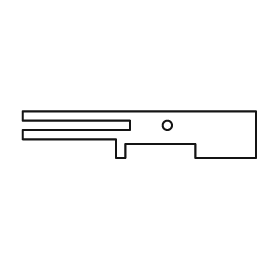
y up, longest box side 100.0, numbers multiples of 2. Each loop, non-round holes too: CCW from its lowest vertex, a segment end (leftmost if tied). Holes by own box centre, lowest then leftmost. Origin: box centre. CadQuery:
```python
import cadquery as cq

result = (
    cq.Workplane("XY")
    .moveTo(-10.0, -10.0)
    .lineTo(-6.0, -10.0)
    .lineTo(-6.0, -4.0)
    .lineTo(24.0, -4.0)
    .lineTo(24.0, -10.0)
    .lineTo(50.0, -10.0)
    .lineTo(50.0, 10.0)
    .lineTo(-50.0, 10.0)
    .lineTo(-50.0, 6.0)
    .lineTo(-4.0, 6.0)
    .lineTo(-4.0, 2.0)
    .lineTo(-50.0, 2.0)
    .lineTo(-50.0, -2.0)
    .lineTo(-10.0, -2.0)
    .close()
    .moveTo(12.0, 4.0)
    .circle(2.0)
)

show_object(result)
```